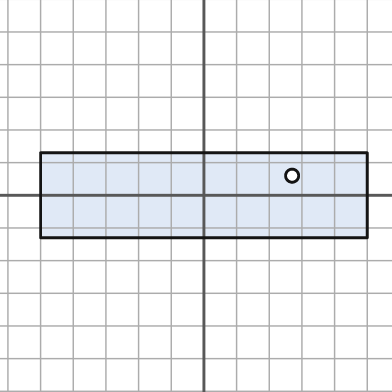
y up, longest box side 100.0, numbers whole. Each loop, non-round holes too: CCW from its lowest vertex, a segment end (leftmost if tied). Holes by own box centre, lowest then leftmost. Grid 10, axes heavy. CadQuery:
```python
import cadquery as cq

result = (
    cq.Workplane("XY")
    .moveTo(-50.0, -13.0)
    .lineTo(50.0, -13.0)
    .lineTo(50.0, 13.0)
    .lineTo(-50.0, 13.0)
    .close()
    .moveTo(27.0, 6.0)
    .circle(2.0)
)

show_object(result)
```